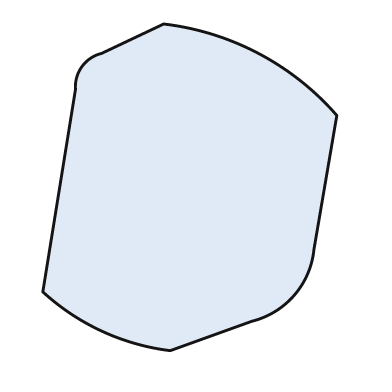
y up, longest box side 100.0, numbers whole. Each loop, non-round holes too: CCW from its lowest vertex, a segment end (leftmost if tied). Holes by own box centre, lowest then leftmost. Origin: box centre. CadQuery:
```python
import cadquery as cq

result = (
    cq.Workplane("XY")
    .moveTo(-6.0, -50.0)
    .lineTo(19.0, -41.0)
    .threePointArc((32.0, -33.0), (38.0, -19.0))
    .lineTo(45.0, 22.0)
    .threePointArc((21.0, 41.0), (-8.0, 50.0))
    .lineTo(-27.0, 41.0)
    .threePointArc((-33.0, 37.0), (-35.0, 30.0))
    .lineTo(-45.0, -32.0)
    .threePointArc((-27.0, -44.0), (-6.0, -50.0))
    .close()
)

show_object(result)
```